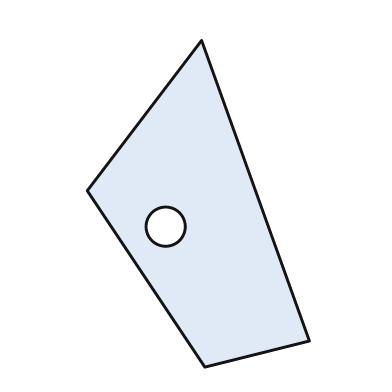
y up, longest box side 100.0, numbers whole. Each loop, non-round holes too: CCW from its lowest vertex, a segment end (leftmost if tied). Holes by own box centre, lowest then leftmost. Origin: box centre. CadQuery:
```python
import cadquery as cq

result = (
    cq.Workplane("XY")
    .moveTo(2.0, -50.0)
    .lineTo(34.0, -42.0)
    .lineTo(1.0, 50.0)
    .lineTo(-34.0, 4.0)
    .close()
    .moveTo(-10.0, -7.0)
    .circle(6.0)
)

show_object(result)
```